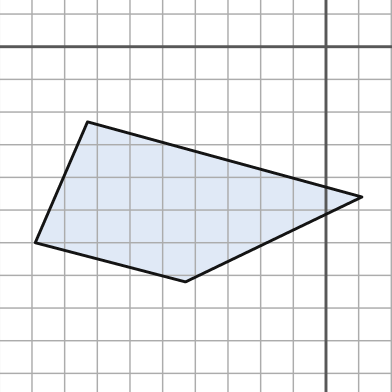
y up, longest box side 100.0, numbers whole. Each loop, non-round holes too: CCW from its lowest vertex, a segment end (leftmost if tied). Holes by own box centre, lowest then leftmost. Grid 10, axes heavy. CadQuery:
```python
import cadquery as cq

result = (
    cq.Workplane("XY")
    .moveTo(-43.0, -72.0)
    .lineTo(11.0, -46.0)
    .lineTo(-73.0, -23.0)
    .lineTo(-89.0, -60.0)
    .close()
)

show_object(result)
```